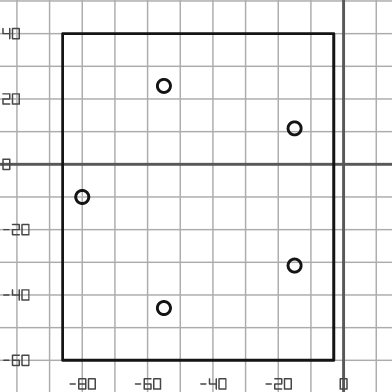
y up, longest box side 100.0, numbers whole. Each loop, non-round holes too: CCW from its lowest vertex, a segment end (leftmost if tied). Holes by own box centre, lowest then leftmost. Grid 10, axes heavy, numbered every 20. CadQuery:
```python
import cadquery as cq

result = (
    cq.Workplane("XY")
    .moveTo(-86.0, -60.0)
    .lineTo(-3.0, -60.0)
    .lineTo(-3.0, 40.0)
    .lineTo(-86.0, 40.0)
    .close()
    .moveTo(-55.0, -44.0)
    .circle(2.0)
    .moveTo(-15.0, -31.0)
    .circle(2.0)
    .moveTo(-80.0, -10.0)
    .circle(2.0)
    .moveTo(-15.0, 11.0)
    .circle(2.0)
    .moveTo(-55.0, 24.0)
    .circle(2.0)
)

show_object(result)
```